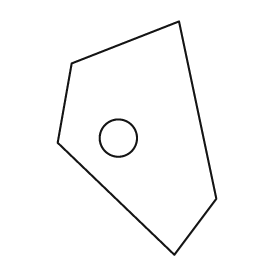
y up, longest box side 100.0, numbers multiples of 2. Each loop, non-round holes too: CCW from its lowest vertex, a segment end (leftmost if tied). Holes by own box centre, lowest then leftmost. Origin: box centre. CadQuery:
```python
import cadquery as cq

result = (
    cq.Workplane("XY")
    .moveTo(16.0, -50.0)
    .lineTo(34.0, -26.0)
    .lineTo(18.0, 50.0)
    .lineTo(-28.0, 32.0)
    .lineTo(-34.0, -2.0)
    .close()
    .moveTo(-8.0, 0.0)
    .circle(8.0)
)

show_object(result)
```